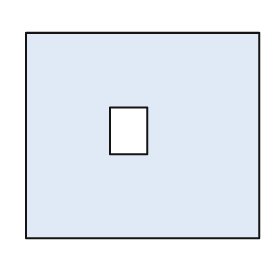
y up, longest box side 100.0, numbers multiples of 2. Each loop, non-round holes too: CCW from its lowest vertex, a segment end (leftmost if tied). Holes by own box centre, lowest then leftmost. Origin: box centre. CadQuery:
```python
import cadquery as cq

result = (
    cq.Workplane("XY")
    .moveTo(-50.0, -44.0)
    .lineTo(50.0, -44.0)
    .lineTo(50.0, 44.0)
    .lineTo(-50.0, 44.0)
    .close()
    .moveTo(-14.0, -8.0)
    .lineTo(2.0, -8.0)
    .lineTo(2.0, 12.0)
    .lineTo(-14.0, 12.0)
    .close()
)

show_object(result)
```